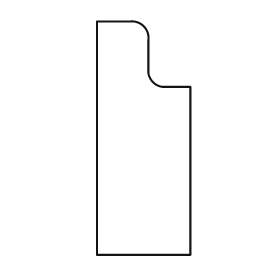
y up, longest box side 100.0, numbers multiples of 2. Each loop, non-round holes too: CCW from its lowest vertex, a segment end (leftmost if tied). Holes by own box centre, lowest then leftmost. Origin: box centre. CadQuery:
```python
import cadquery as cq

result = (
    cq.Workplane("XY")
    .moveTo(-20.0, -50.0)
    .lineTo(20.0, -50.0)
    .lineTo(20.0, 22.0)
    .lineTo(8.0, 22.0)
    .threePointArc((4.0, 24.0), (2.0, 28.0))
    .lineTo(2.0, 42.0)
    .threePointArc((0.0, 48.0), (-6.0, 50.0))
    .lineTo(-20.0, 50.0)
    .close()
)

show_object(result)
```